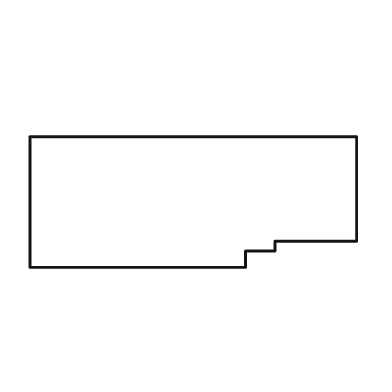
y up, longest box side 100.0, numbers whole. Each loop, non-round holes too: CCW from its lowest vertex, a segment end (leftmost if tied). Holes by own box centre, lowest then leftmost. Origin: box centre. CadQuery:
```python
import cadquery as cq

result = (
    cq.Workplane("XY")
    .moveTo(-50.0, -20.0)
    .lineTo(16.0, -20.0)
    .lineTo(16.0, -15.0)
    .lineTo(25.0, -15.0)
    .lineTo(25.0, -12.0)
    .lineTo(50.0, -12.0)
    .lineTo(50.0, 20.0)
    .lineTo(-50.0, 20.0)
    .close()
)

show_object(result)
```